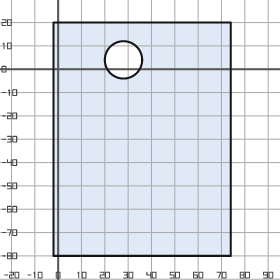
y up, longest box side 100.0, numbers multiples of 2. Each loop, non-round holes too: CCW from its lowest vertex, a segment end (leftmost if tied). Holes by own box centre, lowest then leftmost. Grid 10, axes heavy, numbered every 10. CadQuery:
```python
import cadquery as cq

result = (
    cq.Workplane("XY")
    .moveTo(-2.0, -80.0)
    .lineTo(74.0, -80.0)
    .lineTo(74.0, 20.0)
    .lineTo(-2.0, 20.0)
    .close()
    .moveTo(28.0, 4.0)
    .circle(8.0)
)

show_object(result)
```